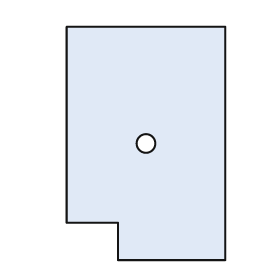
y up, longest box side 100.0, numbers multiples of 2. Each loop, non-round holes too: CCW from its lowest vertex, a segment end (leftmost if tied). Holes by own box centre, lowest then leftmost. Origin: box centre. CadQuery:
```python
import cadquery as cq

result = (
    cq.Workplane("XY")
    .moveTo(-12.0, -50.0)
    .lineTo(34.0, -50.0)
    .lineTo(34.0, 50.0)
    .lineTo(-34.0, 50.0)
    .lineTo(-34.0, -34.0)
    .lineTo(-12.0, -34.0)
    .close()
    .moveTo(0.0, 0.0)
    .circle(4.0)
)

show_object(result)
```